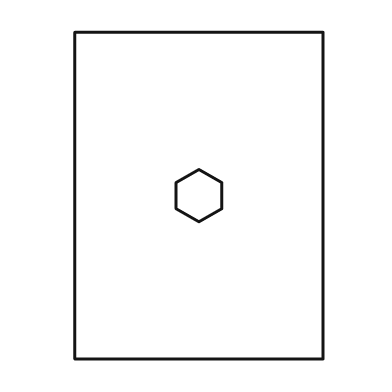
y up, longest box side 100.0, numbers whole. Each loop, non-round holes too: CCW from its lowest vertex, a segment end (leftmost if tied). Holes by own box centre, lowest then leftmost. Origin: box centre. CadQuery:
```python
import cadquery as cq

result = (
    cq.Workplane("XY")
    .moveTo(-38.0, -50.0)
    .lineTo(38.0, -50.0)
    .lineTo(38.0, 50.0)
    .lineTo(-38.0, 50.0)
    .close()
    .moveTo(0.0, -8.0)
    .lineTo(7.0, -4.0)
    .lineTo(7.0, 4.0)
    .lineTo(0.0, 8.0)
    .lineTo(-7.0, 4.0)
    .lineTo(-7.0, -4.0)
    .close()
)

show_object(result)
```